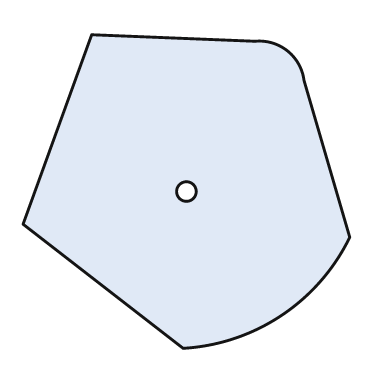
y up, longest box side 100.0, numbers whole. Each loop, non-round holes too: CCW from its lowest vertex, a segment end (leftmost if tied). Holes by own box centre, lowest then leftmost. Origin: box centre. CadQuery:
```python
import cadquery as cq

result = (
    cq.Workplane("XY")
    .moveTo(-1.0, -48.0)
    .threePointArc((29.0, -38.0), (50.0, -14.0))
    .lineTo(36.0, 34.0)
    .threePointArc((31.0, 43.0), (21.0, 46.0))
    .lineTo(-29.0, 48.0)
    .lineTo(-50.0, -10.0)
    .close()
    .moveTo(0.0, 0.0)
    .circle(3.0)
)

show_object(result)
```